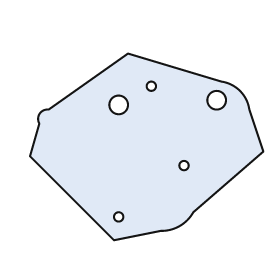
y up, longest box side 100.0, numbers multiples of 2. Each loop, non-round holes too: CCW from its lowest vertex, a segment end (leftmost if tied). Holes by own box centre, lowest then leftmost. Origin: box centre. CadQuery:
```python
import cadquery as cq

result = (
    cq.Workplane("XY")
    .moveTo(-14.0, -40.0)
    .lineTo(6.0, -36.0)
    .threePointArc((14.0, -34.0), (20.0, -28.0))
    .lineTo(50.0, -2.0)
    .lineTo(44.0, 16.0)
    .threePointArc((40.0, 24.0), (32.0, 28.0))
    .lineTo(-8.0, 40.0)
    .lineTo(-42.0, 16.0)
    .threePointArc((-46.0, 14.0), (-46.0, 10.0))
    .lineTo(-50.0, -4.0)
    .close()
    .moveTo(-12.0, -30.0)
    .circle(2.0)
    .moveTo(16.0, -8.0)
    .circle(2.0)
    .moveTo(-12.0, 18.0)
    .circle(4.0)
    .moveTo(30.0, 20.0)
    .circle(4.0)
    .moveTo(2.0, 26.0)
    .circle(2.0)
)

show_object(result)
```